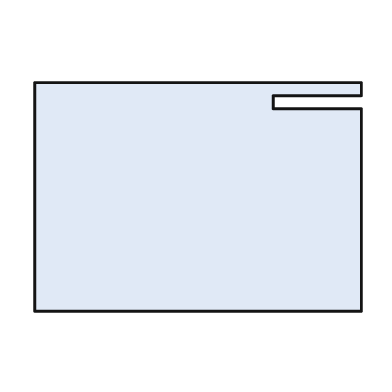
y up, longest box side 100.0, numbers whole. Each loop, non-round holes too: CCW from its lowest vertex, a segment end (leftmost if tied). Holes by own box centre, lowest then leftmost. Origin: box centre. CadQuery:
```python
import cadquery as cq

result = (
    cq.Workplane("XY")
    .moveTo(-50.0, -35.0)
    .lineTo(50.0, -35.0)
    .lineTo(50.0, 27.0)
    .lineTo(23.0, 27.0)
    .lineTo(23.0, 31.0)
    .lineTo(50.0, 31.0)
    .lineTo(50.0, 35.0)
    .lineTo(-50.0, 35.0)
    .close()
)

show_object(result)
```